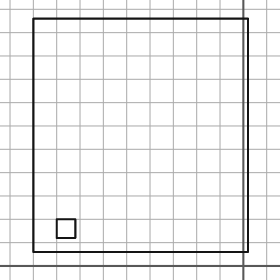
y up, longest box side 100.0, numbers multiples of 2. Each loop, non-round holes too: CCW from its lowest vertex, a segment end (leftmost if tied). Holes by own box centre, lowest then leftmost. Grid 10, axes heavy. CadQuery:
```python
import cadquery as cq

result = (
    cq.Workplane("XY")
    .moveTo(-90.0, 6.0)
    .lineTo(2.0, 6.0)
    .lineTo(2.0, 106.0)
    .lineTo(-90.0, 106.0)
    .close()
    .moveTo(-80.0, 12.0)
    .lineTo(-72.0, 12.0)
    .lineTo(-72.0, 20.0)
    .lineTo(-80.0, 20.0)
    .close()
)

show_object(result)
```